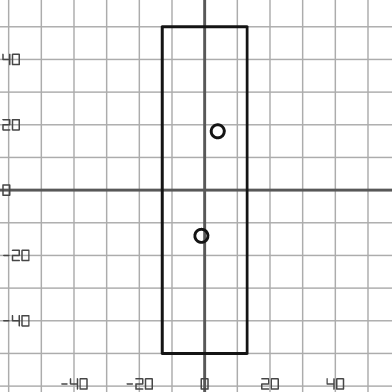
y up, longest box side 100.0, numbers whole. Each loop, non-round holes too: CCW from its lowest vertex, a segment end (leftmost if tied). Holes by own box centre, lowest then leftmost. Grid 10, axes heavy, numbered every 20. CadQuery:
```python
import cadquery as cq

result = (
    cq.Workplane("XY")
    .moveTo(-13.0, -50.0)
    .lineTo(13.0, -50.0)
    .lineTo(13.0, 50.0)
    .lineTo(-13.0, 50.0)
    .close()
    .moveTo(-1.0, -14.0)
    .circle(2.0)
    .moveTo(4.0, 18.0)
    .circle(2.0)
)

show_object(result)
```